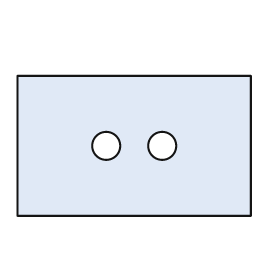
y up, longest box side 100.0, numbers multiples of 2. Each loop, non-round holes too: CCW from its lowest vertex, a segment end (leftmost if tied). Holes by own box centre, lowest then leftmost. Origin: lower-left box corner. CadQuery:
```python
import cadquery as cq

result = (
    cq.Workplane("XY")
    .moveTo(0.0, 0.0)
    .lineTo(100.0, 0.0)
    .lineTo(100.0, 60.0)
    .lineTo(0.0, 60.0)
    .close()
    .moveTo(38.0, 30.0)
    .circle(6.0)
    .moveTo(62.0, 30.0)
    .circle(6.0)
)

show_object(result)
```